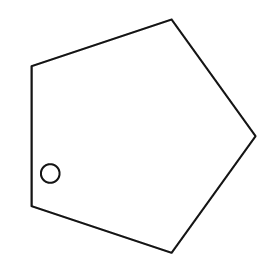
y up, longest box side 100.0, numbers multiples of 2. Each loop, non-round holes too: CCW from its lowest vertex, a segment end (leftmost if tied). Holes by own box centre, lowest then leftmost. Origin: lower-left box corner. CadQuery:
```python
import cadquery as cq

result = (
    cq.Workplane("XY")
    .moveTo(60.0, 0.0)
    .lineTo(96.0, 50.0)
    .lineTo(60.0, 100.0)
    .lineTo(0.0, 80.0)
    .lineTo(0.0, 20.0)
    .close()
    .moveTo(8.0, 34.0)
    .circle(4.0)
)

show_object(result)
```